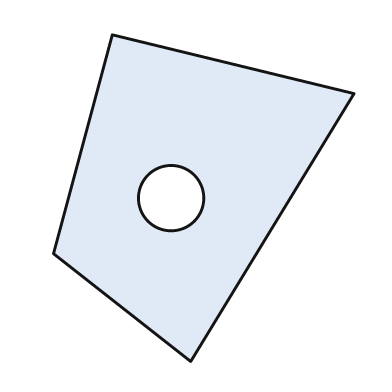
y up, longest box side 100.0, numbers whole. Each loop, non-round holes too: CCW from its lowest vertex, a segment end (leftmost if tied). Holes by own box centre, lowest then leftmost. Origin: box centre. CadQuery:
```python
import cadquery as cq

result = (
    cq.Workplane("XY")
    .moveTo(-4.0, -50.0)
    .lineTo(46.0, 32.0)
    .lineTo(-28.0, 50.0)
    .lineTo(-46.0, -17.0)
    .close()
    .moveTo(-10.0, 0.0)
    .circle(10.0)
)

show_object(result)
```